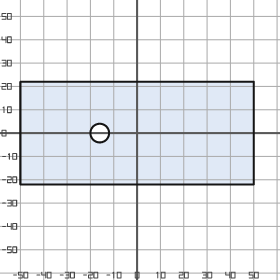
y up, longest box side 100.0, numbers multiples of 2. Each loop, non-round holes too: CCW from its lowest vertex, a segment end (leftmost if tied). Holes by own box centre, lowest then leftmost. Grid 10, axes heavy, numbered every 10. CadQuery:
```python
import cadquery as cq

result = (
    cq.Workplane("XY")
    .moveTo(-50.0, -22.0)
    .lineTo(50.0, -22.0)
    .lineTo(50.0, 22.0)
    .lineTo(-50.0, 22.0)
    .close()
    .moveTo(-16.0, 0.0)
    .circle(4.0)
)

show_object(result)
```